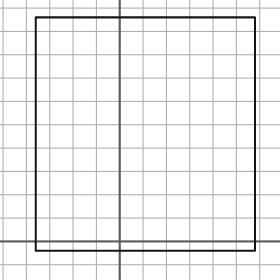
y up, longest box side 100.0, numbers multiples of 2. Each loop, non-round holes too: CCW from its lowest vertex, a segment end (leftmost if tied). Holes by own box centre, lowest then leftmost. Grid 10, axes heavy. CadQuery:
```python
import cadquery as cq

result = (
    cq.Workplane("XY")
    .moveTo(-36.0, -4.0)
    .lineTo(58.0, -4.0)
    .lineTo(58.0, 96.0)
    .lineTo(-36.0, 96.0)
    .close()
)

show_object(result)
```